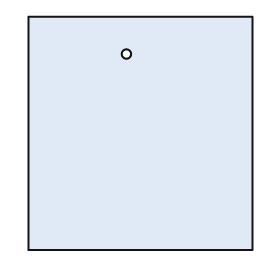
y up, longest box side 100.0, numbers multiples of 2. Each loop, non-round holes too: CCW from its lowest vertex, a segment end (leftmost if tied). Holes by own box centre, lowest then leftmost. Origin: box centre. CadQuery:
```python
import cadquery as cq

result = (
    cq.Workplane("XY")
    .moveTo(-48.0, -50.0)
    .lineTo(48.0, -50.0)
    .lineTo(48.0, 50.0)
    .lineTo(-48.0, 50.0)
    .close()
    .moveTo(-6.0, 34.0)
    .circle(2.0)
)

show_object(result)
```